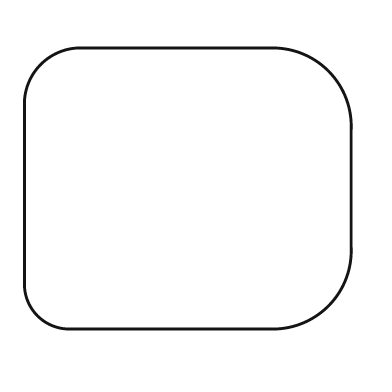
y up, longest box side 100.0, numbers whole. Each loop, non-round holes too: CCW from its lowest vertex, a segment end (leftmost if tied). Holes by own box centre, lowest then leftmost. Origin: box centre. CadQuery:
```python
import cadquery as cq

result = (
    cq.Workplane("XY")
    .moveTo(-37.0, -43.0)
    .lineTo(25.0, -43.0)
    .threePointArc((43.0, -36.0), (50.0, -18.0))
    .lineTo(50.0, 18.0)
    .threePointArc((43.0, 36.0), (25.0, 43.0))
    .lineTo(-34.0, 43.0)
    .threePointArc((-45.0, 38.0), (-50.0, 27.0))
    .lineTo(-50.0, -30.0)
    .threePointArc((-46.0, -39.0), (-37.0, -43.0))
    .close()
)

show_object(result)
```